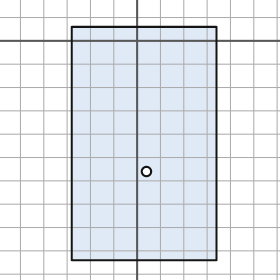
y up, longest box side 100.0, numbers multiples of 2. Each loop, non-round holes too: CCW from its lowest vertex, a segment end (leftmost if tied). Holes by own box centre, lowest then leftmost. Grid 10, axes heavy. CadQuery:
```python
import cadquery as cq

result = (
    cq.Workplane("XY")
    .moveTo(-28.0, -94.0)
    .lineTo(34.0, -94.0)
    .lineTo(34.0, 6.0)
    .lineTo(-28.0, 6.0)
    .close()
    .moveTo(4.0, -56.0)
    .circle(2.0)
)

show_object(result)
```